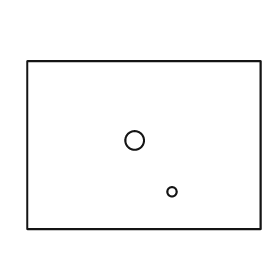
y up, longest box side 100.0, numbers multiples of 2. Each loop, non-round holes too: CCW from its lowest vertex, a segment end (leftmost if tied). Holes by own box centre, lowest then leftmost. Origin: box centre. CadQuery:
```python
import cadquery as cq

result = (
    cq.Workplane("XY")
    .moveTo(-50.0, -36.0)
    .lineTo(50.0, -36.0)
    .lineTo(50.0, 36.0)
    .lineTo(-50.0, 36.0)
    .close()
    .moveTo(12.0, -20.0)
    .circle(2.0)
    .moveTo(-4.0, 2.0)
    .circle(4.0)
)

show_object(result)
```